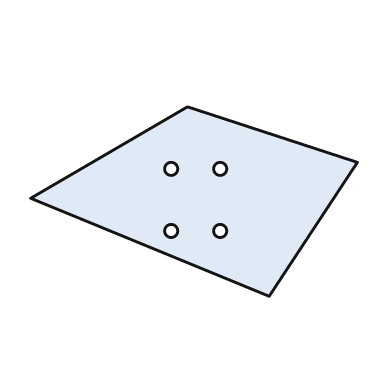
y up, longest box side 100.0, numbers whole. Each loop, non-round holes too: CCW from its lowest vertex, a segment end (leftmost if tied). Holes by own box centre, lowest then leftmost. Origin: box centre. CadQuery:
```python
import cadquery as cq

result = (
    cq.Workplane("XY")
    .moveTo(23.0, -29.0)
    .lineTo(50.0, 12.0)
    .lineTo(-2.0, 29.0)
    .lineTo(-50.0, 1.0)
    .close()
    .moveTo(-7.0, -9.0)
    .circle(2.0)
    .moveTo(8.0, -9.0)
    .circle(2.0)
    .moveTo(-7.0, 10.0)
    .circle(2.0)
    .moveTo(8.0, 10.0)
    .circle(2.0)
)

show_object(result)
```